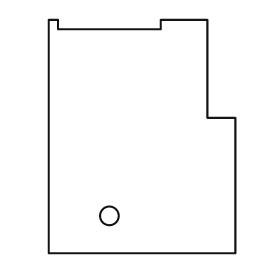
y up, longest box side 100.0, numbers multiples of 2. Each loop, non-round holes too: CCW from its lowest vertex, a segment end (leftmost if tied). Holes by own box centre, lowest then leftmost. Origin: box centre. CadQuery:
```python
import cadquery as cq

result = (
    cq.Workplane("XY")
    .moveTo(-40.0, -50.0)
    .lineTo(40.0, -50.0)
    .lineTo(40.0, 8.0)
    .lineTo(28.0, 8.0)
    .lineTo(28.0, 50.0)
    .lineTo(8.0, 50.0)
    .lineTo(8.0, 46.0)
    .lineTo(-36.0, 46.0)
    .lineTo(-36.0, 50.0)
    .lineTo(-40.0, 50.0)
    .close()
    .moveTo(-14.0, -34.0)
    .circle(4.0)
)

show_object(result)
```